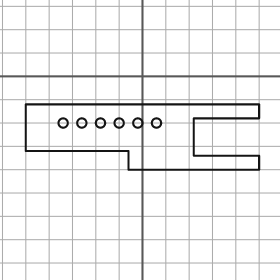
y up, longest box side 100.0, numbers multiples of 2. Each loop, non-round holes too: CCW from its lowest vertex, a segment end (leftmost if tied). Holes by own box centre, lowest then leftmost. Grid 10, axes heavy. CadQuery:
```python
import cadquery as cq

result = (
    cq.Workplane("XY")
    .moveTo(-6.0, -40.0)
    .lineTo(50.0, -40.0)
    .lineTo(50.0, -34.0)
    .lineTo(22.0, -34.0)
    .lineTo(22.0, -18.0)
    .lineTo(50.0, -18.0)
    .lineTo(50.0, -12.0)
    .lineTo(-50.0, -12.0)
    .lineTo(-50.0, -32.0)
    .lineTo(-6.0, -32.0)
    .close()
    .moveTo(-34.0, -20.0)
    .circle(2.0)
    .moveTo(-26.0, -20.0)
    .circle(2.0)
    .moveTo(-18.0, -20.0)
    .circle(2.0)
    .moveTo(-10.0, -20.0)
    .circle(2.0)
    .moveTo(-2.0, -20.0)
    .circle(2.0)
    .moveTo(6.0, -20.0)
    .circle(2.0)
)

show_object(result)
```